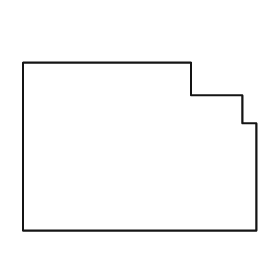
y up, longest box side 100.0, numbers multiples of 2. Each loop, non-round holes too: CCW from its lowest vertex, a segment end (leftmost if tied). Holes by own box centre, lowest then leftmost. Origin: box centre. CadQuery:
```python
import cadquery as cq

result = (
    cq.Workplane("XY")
    .moveTo(-50.0, -36.0)
    .lineTo(50.0, -36.0)
    .lineTo(50.0, 10.0)
    .lineTo(44.0, 10.0)
    .lineTo(44.0, 22.0)
    .lineTo(22.0, 22.0)
    .lineTo(22.0, 36.0)
    .lineTo(-50.0, 36.0)
    .close()
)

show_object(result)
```